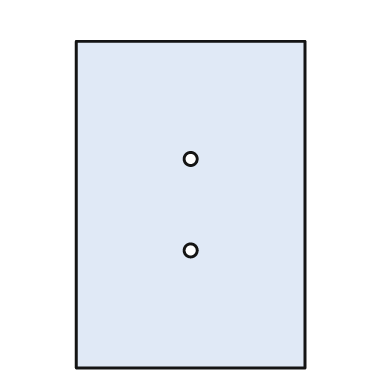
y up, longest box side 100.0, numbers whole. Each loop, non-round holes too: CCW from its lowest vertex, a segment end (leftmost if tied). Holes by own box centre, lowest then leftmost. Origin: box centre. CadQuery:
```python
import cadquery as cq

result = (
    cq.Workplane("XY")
    .moveTo(-35.0, -50.0)
    .lineTo(35.0, -50.0)
    .lineTo(35.0, 50.0)
    .lineTo(-35.0, 50.0)
    .close()
    .moveTo(0.0, -14.0)
    .circle(2.0)
    .moveTo(0.0, 14.0)
    .circle(2.0)
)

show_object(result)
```